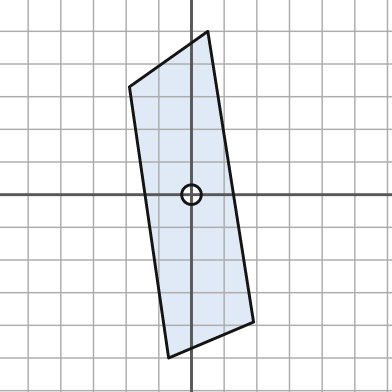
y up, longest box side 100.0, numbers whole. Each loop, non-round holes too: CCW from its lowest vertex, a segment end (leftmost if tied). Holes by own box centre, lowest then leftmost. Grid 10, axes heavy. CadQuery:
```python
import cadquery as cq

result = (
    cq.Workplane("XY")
    .moveTo(-7.0, -50.0)
    .lineTo(19.0, -39.0)
    .lineTo(5.0, 50.0)
    .lineTo(-19.0, 33.0)
    .close()
    .moveTo(0.0, 0.0)
    .circle(3.0)
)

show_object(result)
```